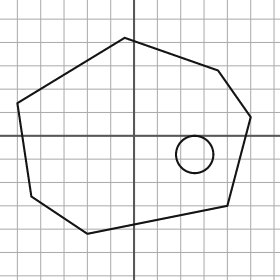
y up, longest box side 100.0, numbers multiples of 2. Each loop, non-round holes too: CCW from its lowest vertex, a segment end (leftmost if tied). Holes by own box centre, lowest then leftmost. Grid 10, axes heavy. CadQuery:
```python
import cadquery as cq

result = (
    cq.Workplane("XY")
    .moveTo(-20.0, -42.0)
    .lineTo(40.0, -30.0)
    .lineTo(50.0, 8.0)
    .lineTo(36.0, 28.0)
    .lineTo(-4.0, 42.0)
    .lineTo(-50.0, 14.0)
    .lineTo(-44.0, -26.0)
    .close()
    .moveTo(26.0, -8.0)
    .circle(8.0)
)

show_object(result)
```